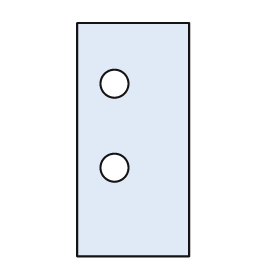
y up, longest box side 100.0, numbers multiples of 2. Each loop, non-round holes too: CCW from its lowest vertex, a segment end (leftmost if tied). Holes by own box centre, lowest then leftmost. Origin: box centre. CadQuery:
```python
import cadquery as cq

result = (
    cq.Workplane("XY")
    .moveTo(-24.0, -50.0)
    .lineTo(24.0, -50.0)
    .lineTo(24.0, 50.0)
    .lineTo(-24.0, 50.0)
    .close()
    .moveTo(-8.0, -12.0)
    .circle(6.0)
    .moveTo(-8.0, 24.0)
    .circle(6.0)
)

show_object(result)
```